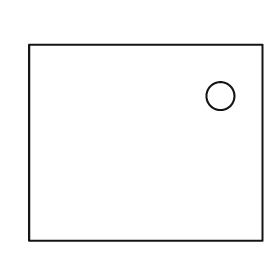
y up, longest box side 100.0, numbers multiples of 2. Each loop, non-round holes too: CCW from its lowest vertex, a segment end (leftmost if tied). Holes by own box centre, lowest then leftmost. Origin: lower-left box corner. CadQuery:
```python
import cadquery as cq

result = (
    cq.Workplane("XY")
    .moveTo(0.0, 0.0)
    .lineTo(100.0, 0.0)
    .lineTo(100.0, 84.0)
    .lineTo(0.0, 84.0)
    .close()
    .moveTo(82.0, 62.0)
    .circle(6.0)
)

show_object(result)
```